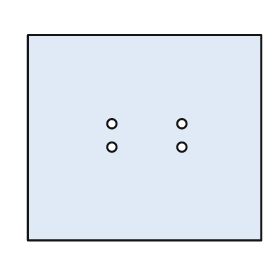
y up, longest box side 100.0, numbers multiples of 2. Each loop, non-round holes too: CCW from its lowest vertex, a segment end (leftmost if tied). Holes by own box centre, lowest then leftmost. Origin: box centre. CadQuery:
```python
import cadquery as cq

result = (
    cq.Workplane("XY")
    .moveTo(-50.0, -44.0)
    .lineTo(50.0, -44.0)
    .lineTo(50.0, 44.0)
    .lineTo(-50.0, 44.0)
    .close()
    .moveTo(-14.0, -4.0)
    .circle(2.0)
    .moveTo(16.0, -4.0)
    .circle(2.0)
    .moveTo(-14.0, 6.0)
    .circle(2.0)
    .moveTo(16.0, 6.0)
    .circle(2.0)
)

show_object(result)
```